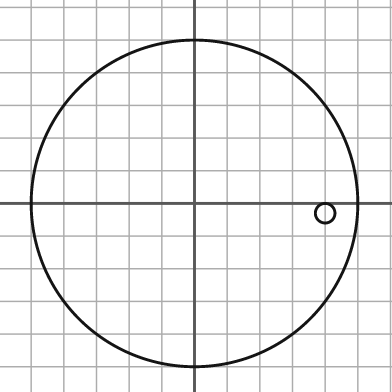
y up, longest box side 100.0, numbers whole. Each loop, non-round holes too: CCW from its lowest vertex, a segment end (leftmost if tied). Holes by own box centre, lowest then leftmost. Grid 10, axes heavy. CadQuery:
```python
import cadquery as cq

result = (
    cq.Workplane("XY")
    .moveTo(0.0, 0.0)
    .circle(50.0)
    .moveTo(40.0, -3.0)
    .circle(3.0)
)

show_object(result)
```